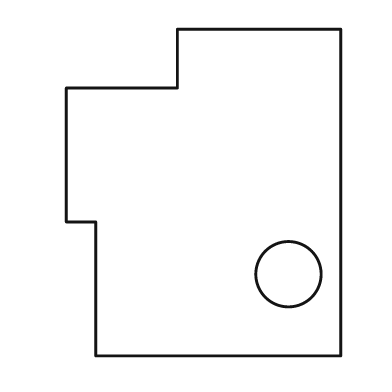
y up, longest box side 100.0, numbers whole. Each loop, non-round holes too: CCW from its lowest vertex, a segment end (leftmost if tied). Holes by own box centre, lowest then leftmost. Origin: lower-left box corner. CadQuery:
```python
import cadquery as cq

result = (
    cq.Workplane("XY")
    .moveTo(9.0, 0.0)
    .lineTo(84.0, 0.0)
    .lineTo(84.0, 100.0)
    .lineTo(34.0, 100.0)
    .lineTo(34.0, 82.0)
    .lineTo(0.0, 82.0)
    .lineTo(0.0, 41.0)
    .lineTo(9.0, 41.0)
    .close()
    .moveTo(68.0, 25.0)
    .circle(10.0)
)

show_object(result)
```